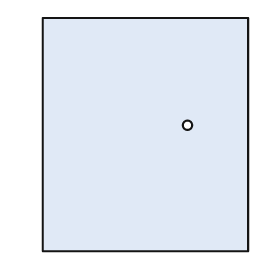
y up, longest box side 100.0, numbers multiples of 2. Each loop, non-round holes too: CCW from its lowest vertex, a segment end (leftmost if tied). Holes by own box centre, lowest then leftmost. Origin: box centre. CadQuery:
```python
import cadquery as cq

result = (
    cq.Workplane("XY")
    .moveTo(-44.0, -50.0)
    .lineTo(44.0, -50.0)
    .lineTo(44.0, 50.0)
    .lineTo(-44.0, 50.0)
    .close()
    .moveTo(18.0, 4.0)
    .circle(2.0)
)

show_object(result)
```